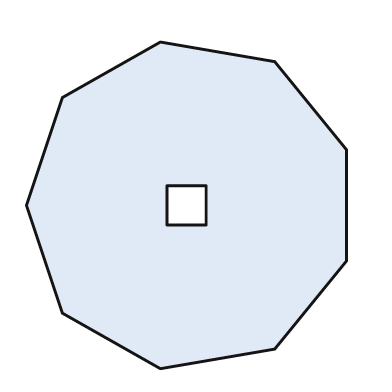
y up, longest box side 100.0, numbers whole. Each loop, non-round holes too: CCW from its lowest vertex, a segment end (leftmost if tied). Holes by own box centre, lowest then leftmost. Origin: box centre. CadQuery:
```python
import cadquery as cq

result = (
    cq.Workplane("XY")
    .moveTo(-8.0, -50.0)
    .lineTo(27.0, -44.0)
    .lineTo(49.0, -17.0)
    .lineTo(49.0, 17.0)
    .lineTo(27.0, 44.0)
    .lineTo(-8.0, 50.0)
    .lineTo(-38.0, 33.0)
    .lineTo(-49.0, 0.0)
    .lineTo(-38.0, -33.0)
    .close()
    .moveTo(-6.0, -6.0)
    .lineTo(6.0, -6.0)
    .lineTo(6.0, 6.0)
    .lineTo(-6.0, 6.0)
    .close()
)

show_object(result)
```